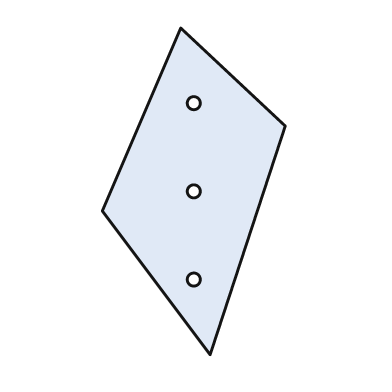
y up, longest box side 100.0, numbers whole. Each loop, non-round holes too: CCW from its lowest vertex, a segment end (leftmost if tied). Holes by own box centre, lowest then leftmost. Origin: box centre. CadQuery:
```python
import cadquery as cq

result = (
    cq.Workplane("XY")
    .moveTo(5.0, -50.0)
    .lineTo(28.0, 20.0)
    .lineTo(-4.0, 50.0)
    .lineTo(-28.0, -6.0)
    .close()
    .moveTo(0.0, -27.0)
    .circle(2.0)
    .moveTo(0.0, 0.0)
    .circle(2.0)
    .moveTo(0.0, 27.0)
    .circle(2.0)
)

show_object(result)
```